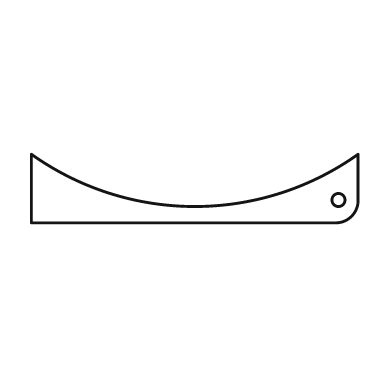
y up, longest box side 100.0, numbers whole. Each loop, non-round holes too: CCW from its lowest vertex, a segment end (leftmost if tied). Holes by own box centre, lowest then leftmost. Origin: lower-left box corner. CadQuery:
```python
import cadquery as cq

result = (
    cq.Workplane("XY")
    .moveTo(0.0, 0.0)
    .lineTo(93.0, 0.0)
    .threePointArc((98.0, 2.0), (100.0, 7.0))
    .lineTo(100.0, 21.0)
    .threePointArc((50.0, 5.0), (0.0, 21.0))
    .close()
    .moveTo(94.0, 7.0)
    .circle(2.0)
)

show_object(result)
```